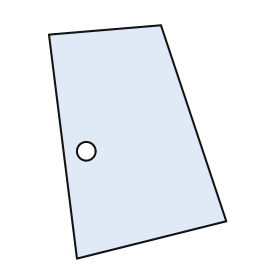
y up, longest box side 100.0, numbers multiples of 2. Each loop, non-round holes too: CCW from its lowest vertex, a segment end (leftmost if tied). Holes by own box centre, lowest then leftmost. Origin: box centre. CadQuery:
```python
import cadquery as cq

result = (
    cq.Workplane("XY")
    .moveTo(-26.0, -50.0)
    .lineTo(38.0, -34.0)
    .lineTo(10.0, 50.0)
    .lineTo(-38.0, 46.0)
    .close()
    .moveTo(-22.0, -4.0)
    .circle(4.0)
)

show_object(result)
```